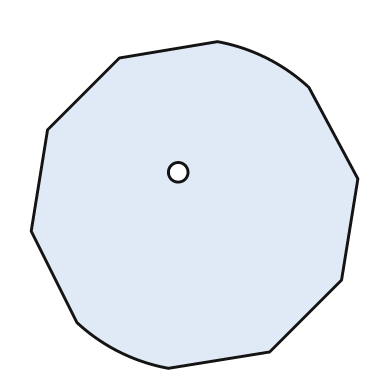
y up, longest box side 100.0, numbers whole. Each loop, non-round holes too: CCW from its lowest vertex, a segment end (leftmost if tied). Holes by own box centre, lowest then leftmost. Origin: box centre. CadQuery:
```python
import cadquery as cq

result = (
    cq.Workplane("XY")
    .moveTo(-8.0, -50.0)
    .lineTo(23.0, -45.0)
    .lineTo(45.0, -23.0)
    .lineTo(50.0, 8.0)
    .lineTo(35.0, 36.0)
    .threePointArc((22.0, 45.0), (7.0, 50.0))
    .lineTo(-23.0, 45.0)
    .lineTo(-45.0, 23.0)
    .lineTo(-50.0, -8.0)
    .lineTo(-36.0, -36.0)
    .threePointArc((-23.0, -45.0), (-8.0, -50.0))
    .close()
    .moveTo(-5.0, 10.0)
    .circle(3.0)
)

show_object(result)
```